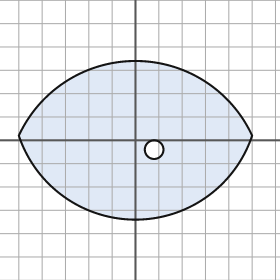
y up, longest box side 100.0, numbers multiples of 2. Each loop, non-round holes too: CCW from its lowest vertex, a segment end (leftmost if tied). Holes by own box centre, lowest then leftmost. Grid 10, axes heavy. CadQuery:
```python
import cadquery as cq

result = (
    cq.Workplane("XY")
    .moveTo(-50.0, 2.0)
    .threePointArc((0.0, -34.0), (50.0, 2.0))
    .threePointArc((0.0, 34.0), (-50.0, 2.0))
    .close()
    .moveTo(8.0, -4.0)
    .circle(4.0)
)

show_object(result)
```